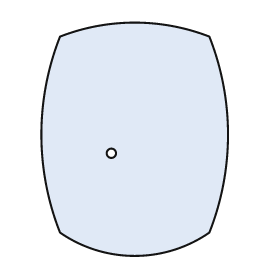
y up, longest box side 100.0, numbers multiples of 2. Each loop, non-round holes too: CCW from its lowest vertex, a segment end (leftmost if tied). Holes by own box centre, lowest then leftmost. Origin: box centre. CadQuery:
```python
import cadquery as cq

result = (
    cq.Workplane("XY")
    .moveTo(-32.0, -40.0)
    .threePointArc((0.0, -50.0), (32.0, -40.0))
    .threePointArc((40.0, 2.0), (32.0, 44.0))
    .threePointArc((0.0, 50.0), (-32.0, 44.0))
    .threePointArc((-40.0, 2.0), (-32.0, -40.0))
    .close()
    .moveTo(-10.0, -6.0)
    .circle(2.0)
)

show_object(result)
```